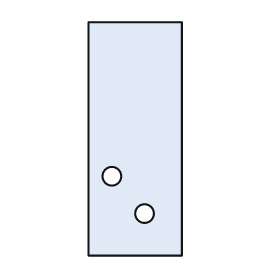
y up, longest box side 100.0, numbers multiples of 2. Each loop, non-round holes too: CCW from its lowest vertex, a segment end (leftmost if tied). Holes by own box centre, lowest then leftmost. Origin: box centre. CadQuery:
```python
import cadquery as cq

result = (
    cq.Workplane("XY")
    .moveTo(-20.0, -50.0)
    .lineTo(20.0, -50.0)
    .lineTo(20.0, 50.0)
    .lineTo(-20.0, 50.0)
    .close()
    .moveTo(4.0, -32.0)
    .circle(4.0)
    .moveTo(-10.0, -16.0)
    .circle(4.0)
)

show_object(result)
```